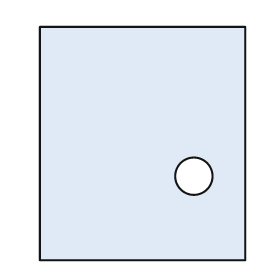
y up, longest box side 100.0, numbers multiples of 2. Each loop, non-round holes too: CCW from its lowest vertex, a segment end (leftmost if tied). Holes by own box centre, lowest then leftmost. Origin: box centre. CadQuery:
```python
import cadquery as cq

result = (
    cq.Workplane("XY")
    .moveTo(-44.0, -50.0)
    .lineTo(44.0, -50.0)
    .lineTo(44.0, 50.0)
    .lineTo(-44.0, 50.0)
    .close()
    .moveTo(22.0, -14.0)
    .circle(8.0)
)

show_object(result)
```